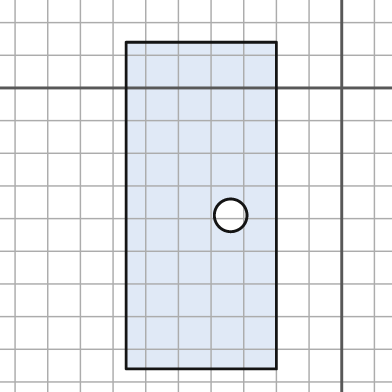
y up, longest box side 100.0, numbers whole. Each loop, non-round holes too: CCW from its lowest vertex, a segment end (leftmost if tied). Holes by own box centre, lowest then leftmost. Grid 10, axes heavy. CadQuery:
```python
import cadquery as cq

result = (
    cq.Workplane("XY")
    .moveTo(-66.0, -86.0)
    .lineTo(-20.0, -86.0)
    .lineTo(-20.0, 14.0)
    .lineTo(-66.0, 14.0)
    .close()
    .moveTo(-34.0, -39.0)
    .circle(5.0)
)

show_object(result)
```